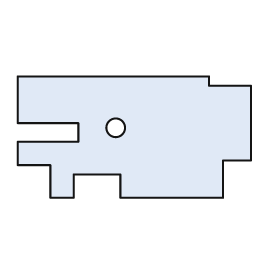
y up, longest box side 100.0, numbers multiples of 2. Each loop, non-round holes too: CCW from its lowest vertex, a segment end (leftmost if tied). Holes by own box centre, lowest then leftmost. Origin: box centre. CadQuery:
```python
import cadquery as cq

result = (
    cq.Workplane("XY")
    .moveTo(-36.0, -26.0)
    .lineTo(-26.0, -26.0)
    .lineTo(-26.0, -16.0)
    .lineTo(-6.0, -16.0)
    .lineTo(-6.0, -26.0)
    .lineTo(38.0, -26.0)
    .lineTo(38.0, -10.0)
    .lineTo(50.0, -10.0)
    .lineTo(50.0, 22.0)
    .lineTo(32.0, 22.0)
    .lineTo(32.0, 26.0)
    .lineTo(-50.0, 26.0)
    .lineTo(-50.0, 6.0)
    .lineTo(-24.0, 6.0)
    .lineTo(-24.0, -2.0)
    .lineTo(-50.0, -2.0)
    .lineTo(-50.0, -12.0)
    .lineTo(-36.0, -12.0)
    .close()
    .moveTo(-8.0, 4.0)
    .circle(4.0)
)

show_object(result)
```